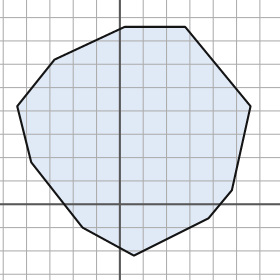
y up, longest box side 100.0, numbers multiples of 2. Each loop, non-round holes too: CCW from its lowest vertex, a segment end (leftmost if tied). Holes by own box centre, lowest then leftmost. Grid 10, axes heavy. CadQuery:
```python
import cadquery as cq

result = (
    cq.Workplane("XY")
    .moveTo(6.0, -22.0)
    .lineTo(38.0, -6.0)
    .lineTo(48.0, 6.0)
    .lineTo(56.0, 42.0)
    .lineTo(28.0, 76.0)
    .lineTo(2.0, 76.0)
    .lineTo(-28.0, 62.0)
    .lineTo(-44.0, 42.0)
    .lineTo(-38.0, 18.0)
    .lineTo(-16.0, -10.0)
    .close()
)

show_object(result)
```